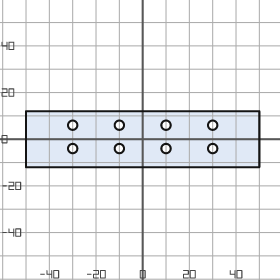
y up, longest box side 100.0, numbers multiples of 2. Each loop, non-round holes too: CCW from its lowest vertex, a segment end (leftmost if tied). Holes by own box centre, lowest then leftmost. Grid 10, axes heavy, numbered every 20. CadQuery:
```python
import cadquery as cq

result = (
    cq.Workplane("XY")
    .moveTo(-50.0, -12.0)
    .lineTo(50.0, -12.0)
    .lineTo(50.0, 12.0)
    .lineTo(-50.0, 12.0)
    .close()
    .moveTo(-30.0, -4.0)
    .circle(2.0)
    .moveTo(-10.0, -4.0)
    .circle(2.0)
    .moveTo(10.0, -4.0)
    .circle(2.0)
    .moveTo(30.0, -4.0)
    .circle(2.0)
    .moveTo(-30.0, 6.0)
    .circle(2.0)
    .moveTo(-10.0, 6.0)
    .circle(2.0)
    .moveTo(10.0, 6.0)
    .circle(2.0)
    .moveTo(30.0, 6.0)
    .circle(2.0)
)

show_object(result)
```